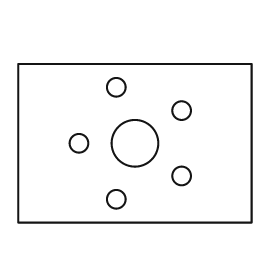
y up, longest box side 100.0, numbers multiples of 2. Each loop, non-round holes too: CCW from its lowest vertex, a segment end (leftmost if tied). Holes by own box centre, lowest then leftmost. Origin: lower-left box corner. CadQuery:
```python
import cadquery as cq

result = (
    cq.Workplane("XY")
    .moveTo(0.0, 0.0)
    .lineTo(100.0, 0.0)
    .lineTo(100.0, 68.0)
    .lineTo(0.0, 68.0)
    .close()
    .moveTo(42.0, 10.0)
    .circle(4.0)
    .moveTo(70.0, 20.0)
    .circle(4.0)
    .moveTo(26.0, 34.0)
    .circle(4.0)
    .moveTo(50.0, 34.0)
    .circle(10.0)
    .moveTo(70.0, 48.0)
    .circle(4.0)
    .moveTo(42.0, 58.0)
    .circle(4.0)
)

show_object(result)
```